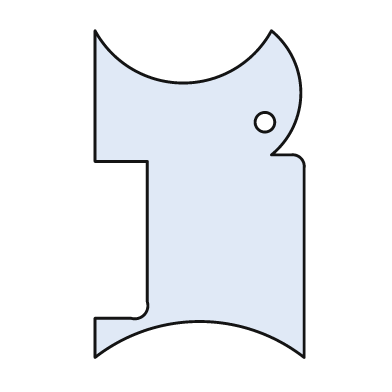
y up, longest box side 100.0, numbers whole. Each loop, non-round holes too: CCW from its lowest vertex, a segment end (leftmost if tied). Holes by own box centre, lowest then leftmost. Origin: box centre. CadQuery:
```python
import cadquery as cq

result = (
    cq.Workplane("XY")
    .moveTo(-32.0, -50.0)
    .threePointArc((0.0, -39.0), (32.0, -50.0))
    .lineTo(32.0, 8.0)
    .threePointArc((31.0, 11.0), (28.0, 12.0))
    .lineTo(22.0, 12.0)
    .threePointArc((31.0, 31.0), (22.0, 50.0))
    .threePointArc((-5.0, 34.0), (-32.0, 50.0))
    .lineTo(-32.0, 10.0)
    .lineTo(-16.0, 10.0)
    .lineTo(-16.0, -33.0)
    .threePointArc((-17.0, -37.0), (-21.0, -38.0))
    .lineTo(-32.0, -38.0)
    .close()
    .moveTo(20.0, 22.0)
    .circle(3.0)
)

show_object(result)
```